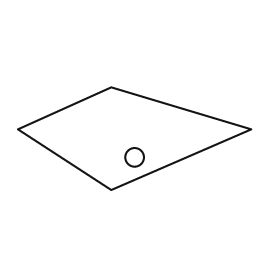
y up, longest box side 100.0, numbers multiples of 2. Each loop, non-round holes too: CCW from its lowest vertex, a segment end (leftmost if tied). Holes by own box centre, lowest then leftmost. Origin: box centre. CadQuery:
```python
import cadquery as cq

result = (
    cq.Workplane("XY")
    .moveTo(-10.0, -22.0)
    .lineTo(50.0, 4.0)
    .lineTo(-10.0, 22.0)
    .lineTo(-50.0, 4.0)
    .close()
    .moveTo(0.0, -8.0)
    .circle(4.0)
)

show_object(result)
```